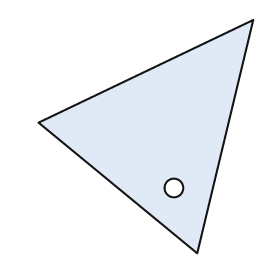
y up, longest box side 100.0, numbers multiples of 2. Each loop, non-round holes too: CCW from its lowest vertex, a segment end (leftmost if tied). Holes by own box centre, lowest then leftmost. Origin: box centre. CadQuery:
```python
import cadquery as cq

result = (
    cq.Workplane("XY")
    .moveTo(22.0, -50.0)
    .lineTo(46.0, 50.0)
    .lineTo(-46.0, 6.0)
    .close()
    .moveTo(12.0, -22.0)
    .circle(4.0)
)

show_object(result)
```